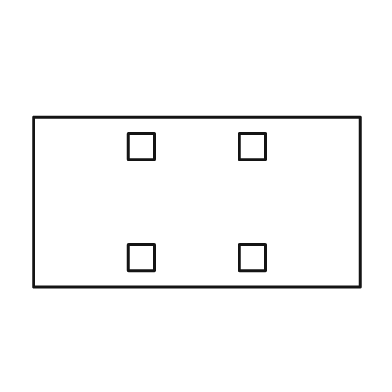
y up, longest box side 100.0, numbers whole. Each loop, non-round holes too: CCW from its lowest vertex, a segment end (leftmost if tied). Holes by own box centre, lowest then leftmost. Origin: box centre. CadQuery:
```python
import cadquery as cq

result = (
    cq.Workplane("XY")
    .moveTo(-50.0, -26.0)
    .lineTo(50.0, -26.0)
    .lineTo(50.0, 26.0)
    .lineTo(-50.0, 26.0)
    .close()
    .moveTo(-21.0, -21.0)
    .lineTo(-13.0, -21.0)
    .lineTo(-13.0, -13.0)
    .lineTo(-21.0, -13.0)
    .close()
    .moveTo(13.0, -21.0)
    .lineTo(21.0, -21.0)
    .lineTo(21.0, -13.0)
    .lineTo(13.0, -13.0)
    .close()
    .moveTo(-21.0, 13.0)
    .lineTo(-13.0, 13.0)
    .lineTo(-13.0, 21.0)
    .lineTo(-21.0, 21.0)
    .close()
    .moveTo(13.0, 13.0)
    .lineTo(21.0, 13.0)
    .lineTo(21.0, 21.0)
    .lineTo(13.0, 21.0)
    .close()
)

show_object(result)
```